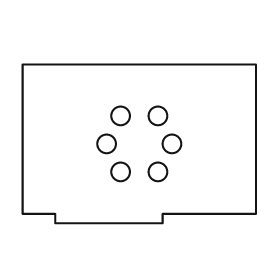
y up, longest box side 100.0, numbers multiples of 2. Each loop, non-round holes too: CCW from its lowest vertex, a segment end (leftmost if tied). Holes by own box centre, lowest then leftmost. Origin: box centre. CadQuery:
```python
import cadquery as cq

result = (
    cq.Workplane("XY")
    .moveTo(-36.0, -34.0)
    .lineTo(10.0, -34.0)
    .lineTo(10.0, -30.0)
    .lineTo(50.0, -30.0)
    .lineTo(50.0, 34.0)
    .lineTo(-50.0, 34.0)
    .lineTo(-50.0, -30.0)
    .lineTo(-36.0, -30.0)
    .close()
    .moveTo(-8.0, -12.0)
    .circle(4.0)
    .moveTo(8.0, -12.0)
    .circle(4.0)
    .moveTo(-14.0, 0.0)
    .circle(4.0)
    .moveTo(14.0, 0.0)
    .circle(4.0)
    .moveTo(-8.0, 12.0)
    .circle(4.0)
    .moveTo(8.0, 12.0)
    .circle(4.0)
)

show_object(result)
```